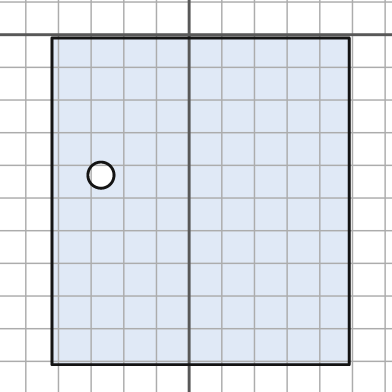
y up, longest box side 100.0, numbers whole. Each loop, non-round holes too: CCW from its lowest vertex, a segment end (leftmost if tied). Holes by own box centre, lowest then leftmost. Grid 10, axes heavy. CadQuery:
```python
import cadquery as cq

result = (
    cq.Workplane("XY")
    .moveTo(-42.0, -101.0)
    .lineTo(49.0, -101.0)
    .lineTo(49.0, -1.0)
    .lineTo(-42.0, -1.0)
    .close()
    .moveTo(-27.0, -43.0)
    .circle(4.0)
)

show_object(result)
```